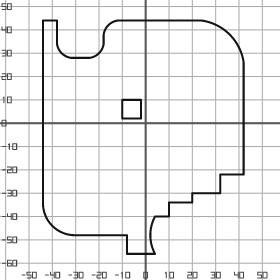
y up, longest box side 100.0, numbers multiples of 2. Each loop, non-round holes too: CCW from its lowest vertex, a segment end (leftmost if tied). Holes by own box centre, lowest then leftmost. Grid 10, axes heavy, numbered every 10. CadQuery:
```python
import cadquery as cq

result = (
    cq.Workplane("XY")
    .moveTo(-8.0, -56.0)
    .lineTo(4.0, -56.0)
    .threePointArc((2.0, -48.0), (4.0, -40.0))
    .lineTo(10.0, -40.0)
    .lineTo(10.0, -34.0)
    .lineTo(20.0, -34.0)
    .lineTo(20.0, -30.0)
    .lineTo(32.0, -30.0)
    .lineTo(32.0, -22.0)
    .lineTo(42.0, -22.0)
    .lineTo(42.0, 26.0)
    .threePointArc((36.0, 38.0), (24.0, 44.0))
    .lineTo(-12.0, 44.0)
    .threePointArc((-16.0, 42.0), (-18.0, 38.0))
    .lineTo(-18.0, 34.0)
    .threePointArc((-20.0, 30.0), (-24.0, 28.0))
    .lineTo(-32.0, 28.0)
    .threePointArc((-36.0, 30.0), (-38.0, 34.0))
    .lineTo(-38.0, 44.0)
    .lineTo(-44.0, 44.0)
    .lineTo(-44.0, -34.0)
    .threePointArc((-40.0, -44.0), (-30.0, -48.0))
    .lineTo(-8.0, -48.0)
    .close()
    .moveTo(-10.0, 2.0)
    .lineTo(-2.0, 2.0)
    .lineTo(-2.0, 10.0)
    .lineTo(-10.0, 10.0)
    .close()
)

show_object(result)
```